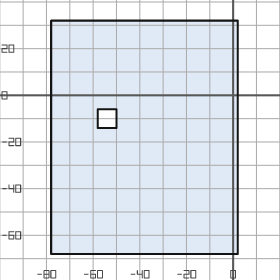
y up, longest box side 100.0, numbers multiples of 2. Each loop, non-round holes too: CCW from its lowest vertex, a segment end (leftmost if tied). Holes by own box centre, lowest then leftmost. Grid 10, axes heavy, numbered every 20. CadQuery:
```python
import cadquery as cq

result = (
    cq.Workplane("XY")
    .moveTo(-78.0, -68.0)
    .lineTo(2.0, -68.0)
    .lineTo(2.0, 32.0)
    .lineTo(-78.0, 32.0)
    .close()
    .moveTo(-58.0, -14.0)
    .lineTo(-50.0, -14.0)
    .lineTo(-50.0, -6.0)
    .lineTo(-58.0, -6.0)
    .close()
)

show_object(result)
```